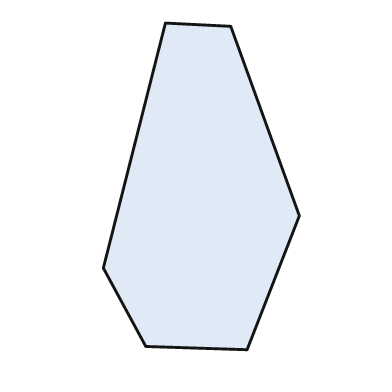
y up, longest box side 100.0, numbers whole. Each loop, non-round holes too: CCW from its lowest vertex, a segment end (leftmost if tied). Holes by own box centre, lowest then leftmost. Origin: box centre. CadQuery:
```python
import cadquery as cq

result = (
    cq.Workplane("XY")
    .moveTo(14.0, -50.0)
    .lineTo(30.0, -9.0)
    .lineTo(9.0, 49.0)
    .lineTo(-11.0, 50.0)
    .lineTo(-30.0, -25.0)
    .lineTo(-17.0, -49.0)
    .close()
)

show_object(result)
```